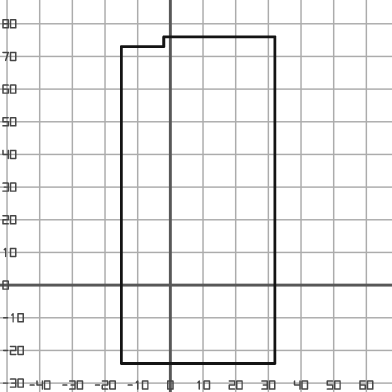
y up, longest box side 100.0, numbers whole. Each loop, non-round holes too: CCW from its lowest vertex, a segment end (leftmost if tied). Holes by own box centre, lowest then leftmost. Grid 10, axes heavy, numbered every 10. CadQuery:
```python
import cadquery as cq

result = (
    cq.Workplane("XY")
    .moveTo(-15.0, -24.0)
    .lineTo(32.0, -24.0)
    .lineTo(32.0, 76.0)
    .lineTo(-2.0, 76.0)
    .lineTo(-2.0, 73.0)
    .lineTo(-15.0, 73.0)
    .close()
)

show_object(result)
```